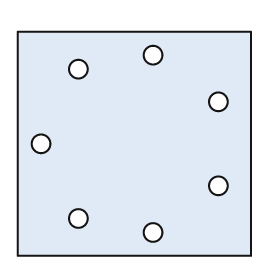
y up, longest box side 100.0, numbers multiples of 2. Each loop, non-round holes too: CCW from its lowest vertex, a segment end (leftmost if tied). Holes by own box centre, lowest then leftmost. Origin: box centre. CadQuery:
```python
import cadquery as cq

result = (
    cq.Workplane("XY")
    .moveTo(-50.0, -48.0)
    .lineTo(50.0, -48.0)
    .lineTo(50.0, 48.0)
    .lineTo(-50.0, 48.0)
    .close()
    .moveTo(8.0, -38.0)
    .circle(4.0)
    .moveTo(-24.0, -32.0)
    .circle(4.0)
    .moveTo(36.0, -18.0)
    .circle(4.0)
    .moveTo(-40.0, 0.0)
    .circle(4.0)
    .moveTo(36.0, 18.0)
    .circle(4.0)
    .moveTo(-24.0, 32.0)
    .circle(4.0)
    .moveTo(8.0, 38.0)
    .circle(4.0)
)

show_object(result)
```